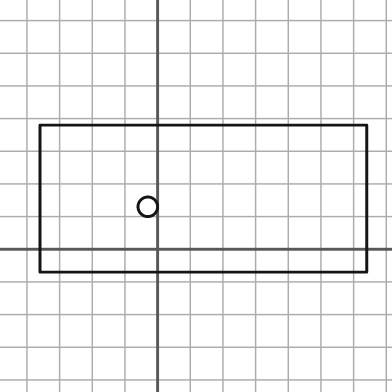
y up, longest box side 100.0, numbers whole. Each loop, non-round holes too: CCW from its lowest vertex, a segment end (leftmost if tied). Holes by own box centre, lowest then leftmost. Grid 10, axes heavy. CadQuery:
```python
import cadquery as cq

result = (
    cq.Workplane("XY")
    .moveTo(-36.0, -7.0)
    .lineTo(64.0, -7.0)
    .lineTo(64.0, 38.0)
    .lineTo(-36.0, 38.0)
    .close()
    .moveTo(-3.0, 13.0)
    .circle(3.0)
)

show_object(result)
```